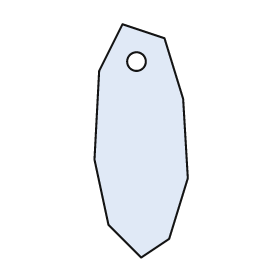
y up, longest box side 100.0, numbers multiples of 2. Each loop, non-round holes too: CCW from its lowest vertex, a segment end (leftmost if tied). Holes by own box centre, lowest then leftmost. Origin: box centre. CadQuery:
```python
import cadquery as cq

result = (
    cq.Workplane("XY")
    .moveTo(0.0, -50.0)
    .lineTo(12.0, -42.0)
    .lineTo(20.0, -16.0)
    .lineTo(18.0, 18.0)
    .lineTo(10.0, 44.0)
    .lineTo(-8.0, 50.0)
    .lineTo(-18.0, 30.0)
    .lineTo(-20.0, -8.0)
    .lineTo(-14.0, -36.0)
    .close()
    .moveTo(-2.0, 34.0)
    .circle(4.0)
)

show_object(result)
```